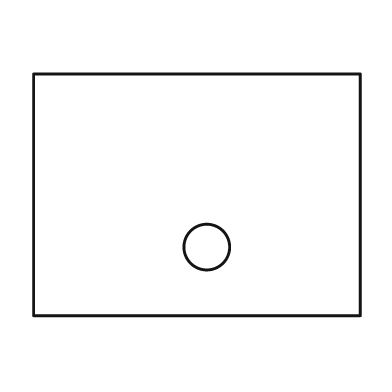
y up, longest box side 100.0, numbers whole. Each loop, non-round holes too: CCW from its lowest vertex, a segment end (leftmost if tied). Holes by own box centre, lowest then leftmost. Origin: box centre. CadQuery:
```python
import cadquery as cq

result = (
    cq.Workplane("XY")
    .moveTo(-50.0, -37.0)
    .lineTo(50.0, -37.0)
    .lineTo(50.0, 37.0)
    .lineTo(-50.0, 37.0)
    .close()
    .moveTo(3.0, -16.0)
    .circle(7.0)
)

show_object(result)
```